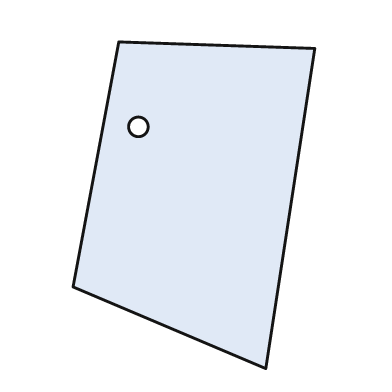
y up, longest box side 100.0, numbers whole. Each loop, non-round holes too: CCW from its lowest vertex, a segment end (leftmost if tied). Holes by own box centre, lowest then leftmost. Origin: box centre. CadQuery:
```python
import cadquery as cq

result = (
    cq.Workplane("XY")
    .moveTo(22.0, -50.0)
    .lineTo(37.0, 48.0)
    .lineTo(-23.0, 50.0)
    .lineTo(-37.0, -25.0)
    .close()
    .moveTo(-17.0, 24.0)
    .circle(3.0)
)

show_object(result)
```